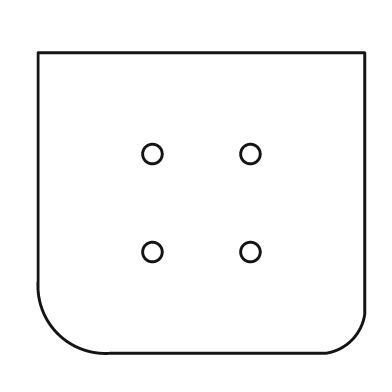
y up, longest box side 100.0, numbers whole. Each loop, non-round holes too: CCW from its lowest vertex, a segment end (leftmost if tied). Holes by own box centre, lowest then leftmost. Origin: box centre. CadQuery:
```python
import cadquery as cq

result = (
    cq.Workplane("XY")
    .moveTo(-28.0, -46.0)
    .lineTo(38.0, -46.0)
    .threePointArc((46.0, -42.0), (50.0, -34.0))
    .lineTo(50.0, 46.0)
    .lineTo(-50.0, 46.0)
    .lineTo(-50.0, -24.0)
    .threePointArc((-44.0, -40.0), (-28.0, -46.0))
    .close()
    .moveTo(-15.0, -15.0)
    .circle(3.0)
    .moveTo(15.0, -15.0)
    .circle(3.0)
    .moveTo(-15.0, 15.0)
    .circle(3.0)
    .moveTo(15.0, 15.0)
    .circle(3.0)
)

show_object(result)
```